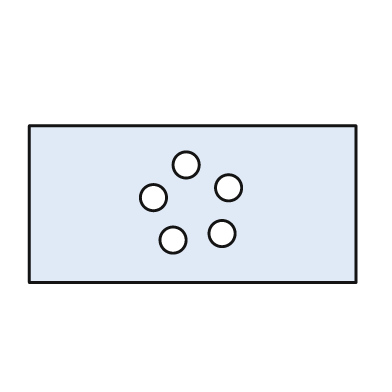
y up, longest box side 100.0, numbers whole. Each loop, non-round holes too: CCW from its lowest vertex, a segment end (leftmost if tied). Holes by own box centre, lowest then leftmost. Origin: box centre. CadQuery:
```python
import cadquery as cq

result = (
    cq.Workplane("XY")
    .moveTo(-50.0, -24.0)
    .lineTo(50.0, -24.0)
    .lineTo(50.0, 24.0)
    .lineTo(-50.0, 24.0)
    .close()
    .moveTo(-6.0, -11.0)
    .circle(4.0)
    .moveTo(9.0, -9.0)
    .circle(4.0)
    .moveTo(-12.0, 2.0)
    .circle(4.0)
    .moveTo(11.0, 5.0)
    .circle(4.0)
    .moveTo(-2.0, 12.0)
    .circle(4.0)
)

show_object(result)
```